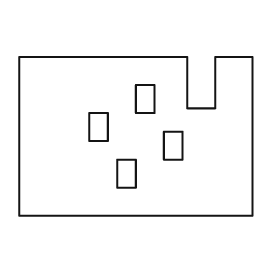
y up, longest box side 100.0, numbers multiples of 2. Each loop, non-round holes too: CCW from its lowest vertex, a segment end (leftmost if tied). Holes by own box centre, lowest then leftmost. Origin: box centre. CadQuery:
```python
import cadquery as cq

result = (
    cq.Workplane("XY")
    .moveTo(-50.0, -34.0)
    .lineTo(50.0, -34.0)
    .lineTo(50.0, 34.0)
    .lineTo(34.0, 34.0)
    .lineTo(34.0, 12.0)
    .lineTo(22.0, 12.0)
    .lineTo(22.0, 34.0)
    .lineTo(-50.0, 34.0)
    .close()
    .moveTo(-8.0, -22.0)
    .lineTo(0.0, -22.0)
    .lineTo(0.0, -10.0)
    .lineTo(-8.0, -10.0)
    .close()
    .moveTo(12.0, -10.0)
    .lineTo(20.0, -10.0)
    .lineTo(20.0, 2.0)
    .lineTo(12.0, 2.0)
    .close()
    .moveTo(-20.0, -2.0)
    .lineTo(-12.0, -2.0)
    .lineTo(-12.0, 10.0)
    .lineTo(-20.0, 10.0)
    .close()
    .moveTo(0.0, 10.0)
    .lineTo(8.0, 10.0)
    .lineTo(8.0, 22.0)
    .lineTo(0.0, 22.0)
    .close()
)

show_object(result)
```